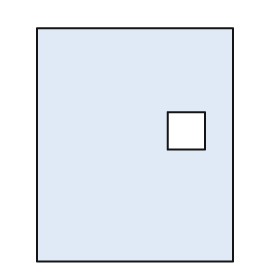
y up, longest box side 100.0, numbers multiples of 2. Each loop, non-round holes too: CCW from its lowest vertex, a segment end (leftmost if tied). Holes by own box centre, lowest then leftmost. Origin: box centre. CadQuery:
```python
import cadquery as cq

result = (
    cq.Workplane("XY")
    .moveTo(-42.0, -50.0)
    .lineTo(42.0, -50.0)
    .lineTo(42.0, 50.0)
    .lineTo(-42.0, 50.0)
    .close()
    .moveTo(14.0, -2.0)
    .lineTo(30.0, -2.0)
    .lineTo(30.0, 14.0)
    .lineTo(14.0, 14.0)
    .close()
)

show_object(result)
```